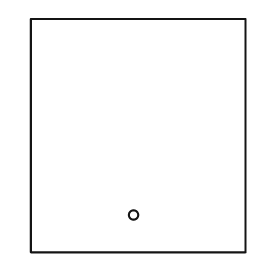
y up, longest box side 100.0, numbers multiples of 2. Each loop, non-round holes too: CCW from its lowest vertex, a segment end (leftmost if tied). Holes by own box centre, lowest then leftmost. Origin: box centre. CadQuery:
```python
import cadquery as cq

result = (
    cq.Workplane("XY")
    .moveTo(-46.0, -50.0)
    .lineTo(46.0, -50.0)
    .lineTo(46.0, 50.0)
    .lineTo(-46.0, 50.0)
    .close()
    .moveTo(-2.0, -34.0)
    .circle(2.0)
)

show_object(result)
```